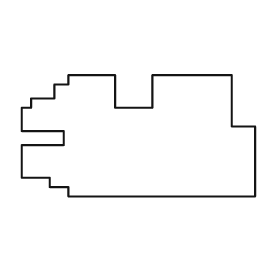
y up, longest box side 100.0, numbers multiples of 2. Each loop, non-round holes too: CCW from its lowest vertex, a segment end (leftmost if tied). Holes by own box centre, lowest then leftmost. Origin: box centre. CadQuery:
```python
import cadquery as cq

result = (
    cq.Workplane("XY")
    .moveTo(-30.0, -26.0)
    .lineTo(50.0, -26.0)
    .lineTo(50.0, 4.0)
    .lineTo(40.0, 4.0)
    .lineTo(40.0, 26.0)
    .lineTo(6.0, 26.0)
    .lineTo(6.0, 12.0)
    .lineTo(-10.0, 12.0)
    .lineTo(-10.0, 26.0)
    .lineTo(-30.0, 26.0)
    .lineTo(-30.0, 22.0)
    .lineTo(-36.0, 22.0)
    .lineTo(-36.0, 16.0)
    .lineTo(-46.0, 16.0)
    .lineTo(-46.0, 12.0)
    .lineTo(-50.0, 12.0)
    .lineTo(-50.0, 2.0)
    .lineTo(-32.0, 2.0)
    .lineTo(-32.0, -4.0)
    .lineTo(-50.0, -4.0)
    .lineTo(-50.0, -18.0)
    .lineTo(-38.0, -18.0)
    .lineTo(-38.0, -22.0)
    .lineTo(-30.0, -22.0)
    .close()
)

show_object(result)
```